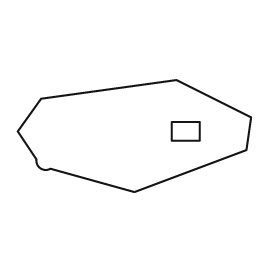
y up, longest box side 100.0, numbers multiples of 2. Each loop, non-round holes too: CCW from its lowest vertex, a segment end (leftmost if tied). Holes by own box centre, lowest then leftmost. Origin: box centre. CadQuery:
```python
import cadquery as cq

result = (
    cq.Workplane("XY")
    .moveTo(0.0, -24.0)
    .lineTo(48.0, -6.0)
    .lineTo(50.0, 8.0)
    .lineTo(18.0, 24.0)
    .lineTo(-40.0, 16.0)
    .lineTo(-50.0, 2.0)
    .lineTo(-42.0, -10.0)
    .threePointArc((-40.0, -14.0), (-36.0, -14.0))
    .close()
    .moveTo(16.0, -2.0)
    .lineTo(28.0, -2.0)
    .lineTo(28.0, 6.0)
    .lineTo(16.0, 6.0)
    .close()
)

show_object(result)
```